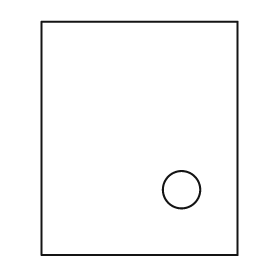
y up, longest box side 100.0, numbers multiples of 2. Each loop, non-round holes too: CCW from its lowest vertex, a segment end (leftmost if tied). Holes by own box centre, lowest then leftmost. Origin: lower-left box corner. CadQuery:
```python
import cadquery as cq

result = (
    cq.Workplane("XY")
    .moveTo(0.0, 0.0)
    .lineTo(84.0, 0.0)
    .lineTo(84.0, 100.0)
    .lineTo(0.0, 100.0)
    .close()
    .moveTo(60.0, 28.0)
    .circle(8.0)
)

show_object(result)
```